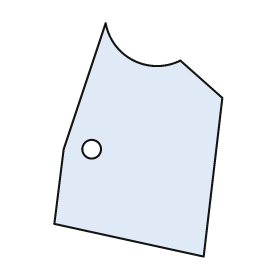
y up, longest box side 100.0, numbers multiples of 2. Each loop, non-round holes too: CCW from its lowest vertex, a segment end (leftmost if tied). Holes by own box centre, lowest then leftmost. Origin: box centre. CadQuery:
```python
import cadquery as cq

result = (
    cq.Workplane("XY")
    .moveTo(28.0, -50.0)
    .lineTo(36.0, 18.0)
    .lineTo(18.0, 34.0)
    .threePointArc((-2.0, 34.0), (-14.0, 50.0))
    .lineTo(-32.0, -4.0)
    .lineTo(-36.0, -36.0)
    .close()
    .moveTo(-20.0, -4.0)
    .circle(4.0)
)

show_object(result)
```